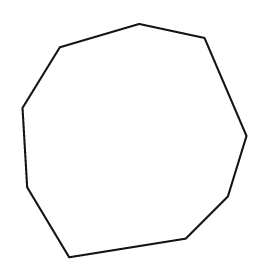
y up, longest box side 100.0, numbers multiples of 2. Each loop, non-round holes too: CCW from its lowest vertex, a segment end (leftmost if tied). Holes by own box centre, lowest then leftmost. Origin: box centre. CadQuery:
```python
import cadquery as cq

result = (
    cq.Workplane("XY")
    .moveTo(-28.0, -50.0)
    .lineTo(22.0, -42.0)
    .lineTo(40.0, -24.0)
    .lineTo(48.0, 2.0)
    .lineTo(30.0, 44.0)
    .lineTo(2.0, 50.0)
    .lineTo(-32.0, 40.0)
    .lineTo(-48.0, 14.0)
    .lineTo(-46.0, -20.0)
    .close()
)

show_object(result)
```